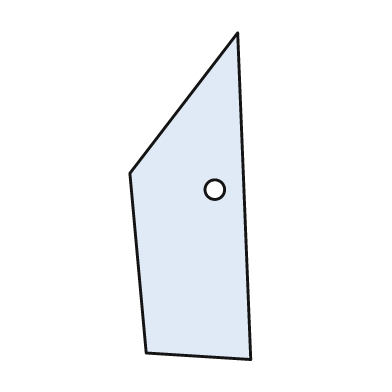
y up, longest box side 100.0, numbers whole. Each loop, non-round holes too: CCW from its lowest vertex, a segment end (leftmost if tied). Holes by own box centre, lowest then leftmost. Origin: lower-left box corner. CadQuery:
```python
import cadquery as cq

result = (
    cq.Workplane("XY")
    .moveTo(37.0, 0.0)
    .lineTo(33.0, 100.0)
    .lineTo(0.0, 57.0)
    .lineTo(5.0, 2.0)
    .close()
    .moveTo(26.0, 52.0)
    .circle(3.0)
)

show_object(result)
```